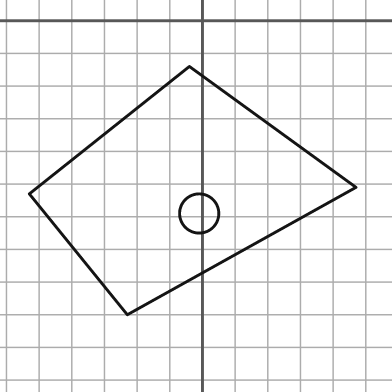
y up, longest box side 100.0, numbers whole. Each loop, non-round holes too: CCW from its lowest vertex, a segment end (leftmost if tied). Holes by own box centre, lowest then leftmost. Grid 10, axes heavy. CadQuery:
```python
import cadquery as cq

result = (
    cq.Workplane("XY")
    .moveTo(-23.0, -90.0)
    .lineTo(47.0, -51.0)
    .lineTo(-4.0, -14.0)
    .lineTo(-53.0, -53.0)
    .close()
    .moveTo(-1.0, -59.0)
    .circle(6.0)
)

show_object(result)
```